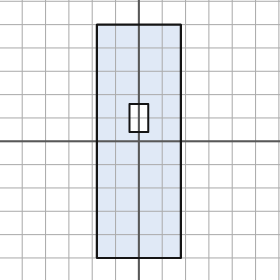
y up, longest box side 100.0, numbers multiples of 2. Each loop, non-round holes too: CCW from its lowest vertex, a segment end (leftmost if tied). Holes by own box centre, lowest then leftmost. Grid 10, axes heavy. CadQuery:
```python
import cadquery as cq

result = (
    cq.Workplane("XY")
    .moveTo(-18.0, -50.0)
    .lineTo(18.0, -50.0)
    .lineTo(18.0, 50.0)
    .lineTo(-18.0, 50.0)
    .close()
    .moveTo(-4.0, 4.0)
    .lineTo(4.0, 4.0)
    .lineTo(4.0, 16.0)
    .lineTo(-4.0, 16.0)
    .close()
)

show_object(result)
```